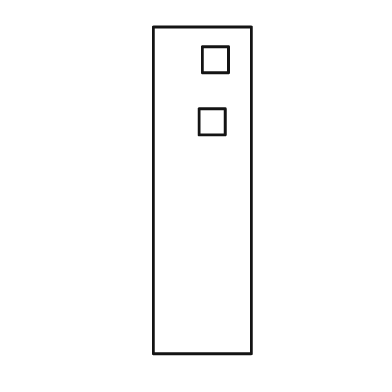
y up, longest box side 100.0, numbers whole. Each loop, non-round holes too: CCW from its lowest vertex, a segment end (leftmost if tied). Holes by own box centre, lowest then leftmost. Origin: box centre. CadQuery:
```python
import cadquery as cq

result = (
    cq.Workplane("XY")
    .moveTo(-15.0, -50.0)
    .lineTo(15.0, -50.0)
    .lineTo(15.0, 50.0)
    .lineTo(-15.0, 50.0)
    .close()
    .moveTo(-1.0, 17.0)
    .lineTo(7.0, 17.0)
    .lineTo(7.0, 25.0)
    .lineTo(-1.0, 25.0)
    .close()
    .moveTo(0.0, 36.0)
    .lineTo(8.0, 36.0)
    .lineTo(8.0, 44.0)
    .lineTo(0.0, 44.0)
    .close()
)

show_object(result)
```